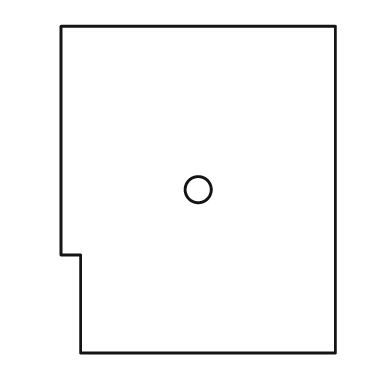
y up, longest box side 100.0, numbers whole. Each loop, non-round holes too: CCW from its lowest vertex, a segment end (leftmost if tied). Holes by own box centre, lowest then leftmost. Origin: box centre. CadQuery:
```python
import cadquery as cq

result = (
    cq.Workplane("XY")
    .moveTo(-36.0, -50.0)
    .lineTo(42.0, -50.0)
    .lineTo(42.0, 50.0)
    .lineTo(-42.0, 50.0)
    .lineTo(-42.0, -20.0)
    .lineTo(-36.0, -20.0)
    .close()
    .moveTo(0.0, 0.0)
    .circle(4.0)
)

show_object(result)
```